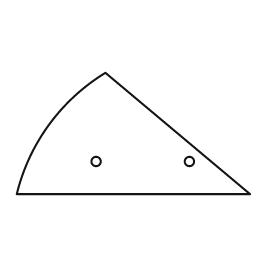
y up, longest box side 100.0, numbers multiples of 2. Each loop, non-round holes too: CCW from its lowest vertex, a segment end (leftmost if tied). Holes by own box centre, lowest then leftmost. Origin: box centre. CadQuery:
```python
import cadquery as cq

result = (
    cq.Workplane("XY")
    .moveTo(-50.0, -26.0)
    .lineTo(50.0, -26.0)
    .lineTo(-12.0, 26.0)
    .threePointArc((-36.0, 4.0), (-50.0, -26.0))
    .close()
    .moveTo(-16.0, -12.0)
    .circle(2.0)
    .moveTo(24.0, -12.0)
    .circle(2.0)
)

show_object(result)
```